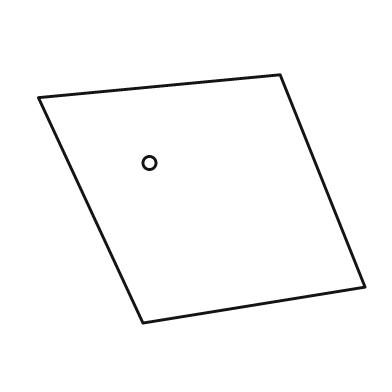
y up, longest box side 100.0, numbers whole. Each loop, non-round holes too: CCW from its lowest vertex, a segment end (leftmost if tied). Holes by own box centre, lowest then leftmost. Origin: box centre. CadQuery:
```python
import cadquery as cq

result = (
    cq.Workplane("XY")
    .moveTo(-18.0, -38.0)
    .lineTo(50.0, -27.0)
    .lineTo(24.0, 38.0)
    .lineTo(-50.0, 31.0)
    .close()
    .moveTo(-16.0, 11.0)
    .circle(2.0)
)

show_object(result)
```